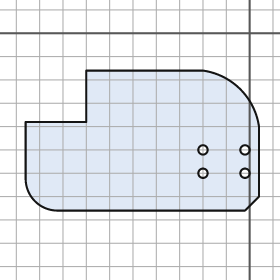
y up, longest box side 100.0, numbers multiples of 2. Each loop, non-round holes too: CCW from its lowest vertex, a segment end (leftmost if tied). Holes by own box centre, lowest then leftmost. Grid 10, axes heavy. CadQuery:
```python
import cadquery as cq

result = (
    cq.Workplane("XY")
    .moveTo(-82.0, -76.0)
    .lineTo(-2.0, -76.0)
    .lineTo(4.0, -70.0)
    .lineTo(4.0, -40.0)
    .threePointArc((-4.0, -24.0), (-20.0, -16.0))
    .lineTo(-70.0, -16.0)
    .lineTo(-70.0, -38.0)
    .lineTo(-96.0, -38.0)
    .lineTo(-96.0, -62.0)
    .threePointArc((-92.0, -72.0), (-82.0, -76.0))
    .close()
    .moveTo(-20.0, -60.0)
    .circle(2.0)
    .moveTo(-2.0, -60.0)
    .circle(2.0)
    .moveTo(-20.0, -50.0)
    .circle(2.0)
    .moveTo(-2.0, -50.0)
    .circle(2.0)
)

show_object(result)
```